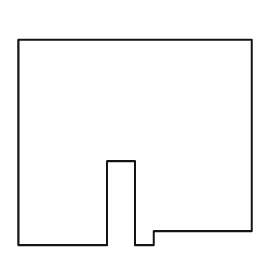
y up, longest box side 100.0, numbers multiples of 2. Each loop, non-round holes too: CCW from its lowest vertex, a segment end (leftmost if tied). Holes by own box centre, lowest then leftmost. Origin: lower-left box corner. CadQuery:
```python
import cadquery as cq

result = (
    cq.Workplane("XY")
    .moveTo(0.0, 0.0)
    .lineTo(38.0, 0.0)
    .lineTo(38.0, 36.0)
    .lineTo(50.0, 36.0)
    .lineTo(50.0, 0.0)
    .lineTo(58.0, 0.0)
    .lineTo(58.0, 6.0)
    .lineTo(100.0, 6.0)
    .lineTo(100.0, 88.0)
    .lineTo(0.0, 88.0)
    .close()
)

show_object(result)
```